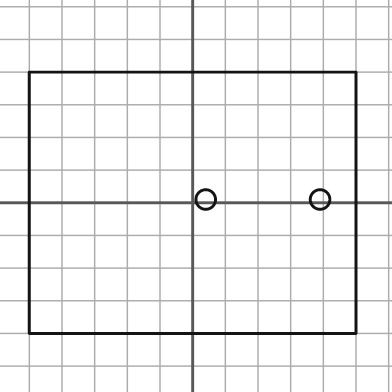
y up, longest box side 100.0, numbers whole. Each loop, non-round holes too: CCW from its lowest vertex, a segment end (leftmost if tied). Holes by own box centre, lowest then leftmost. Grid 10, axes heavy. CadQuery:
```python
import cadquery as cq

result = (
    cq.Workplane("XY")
    .moveTo(-50.0, -40.0)
    .lineTo(50.0, -40.0)
    .lineTo(50.0, 40.0)
    .lineTo(-50.0, 40.0)
    .close()
    .moveTo(4.0, 1.0)
    .circle(3.0)
    .moveTo(39.0, 1.0)
    .circle(3.0)
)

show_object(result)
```